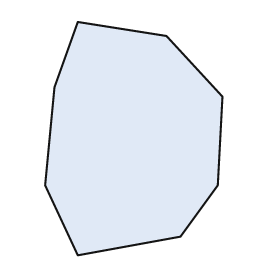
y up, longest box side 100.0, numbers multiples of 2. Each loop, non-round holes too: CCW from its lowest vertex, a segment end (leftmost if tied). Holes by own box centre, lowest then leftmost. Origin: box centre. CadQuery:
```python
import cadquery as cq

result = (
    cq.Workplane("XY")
    .moveTo(-24.0, -50.0)
    .lineTo(20.0, -42.0)
    .lineTo(36.0, -20.0)
    .lineTo(38.0, 18.0)
    .lineTo(14.0, 44.0)
    .lineTo(-24.0, 50.0)
    .lineTo(-34.0, 22.0)
    .lineTo(-38.0, -20.0)
    .close()
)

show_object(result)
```